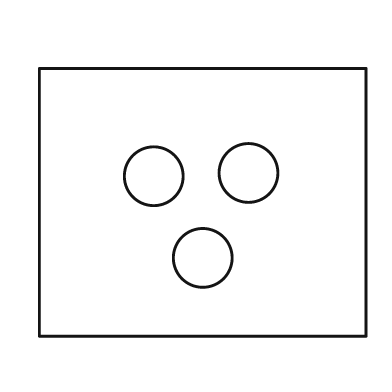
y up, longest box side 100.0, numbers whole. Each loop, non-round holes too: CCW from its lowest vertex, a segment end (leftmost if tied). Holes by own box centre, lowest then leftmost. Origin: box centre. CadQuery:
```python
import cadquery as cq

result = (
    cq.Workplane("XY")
    .moveTo(-50.0, -41.0)
    .lineTo(50.0, -41.0)
    .lineTo(50.0, 41.0)
    .lineTo(-50.0, 41.0)
    .close()
    .moveTo(0.0, -17.0)
    .circle(9.0)
    .moveTo(-15.0, 8.0)
    .circle(9.0)
    .moveTo(14.0, 9.0)
    .circle(9.0)
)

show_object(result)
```